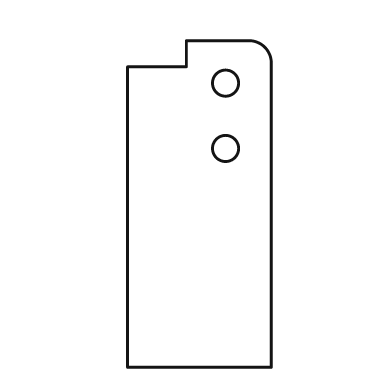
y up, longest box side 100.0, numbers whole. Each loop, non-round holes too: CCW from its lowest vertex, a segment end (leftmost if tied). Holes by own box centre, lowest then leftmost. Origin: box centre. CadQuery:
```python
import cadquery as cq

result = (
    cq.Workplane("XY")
    .moveTo(-22.0, -50.0)
    .lineTo(22.0, -50.0)
    .lineTo(22.0, 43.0)
    .threePointArc((20.0, 48.0), (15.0, 50.0))
    .lineTo(-4.0, 50.0)
    .lineTo(-4.0, 42.0)
    .lineTo(-22.0, 42.0)
    .close()
    .moveTo(8.0, 17.0)
    .circle(4.0)
    .moveTo(8.0, 37.0)
    .circle(4.0)
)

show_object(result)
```